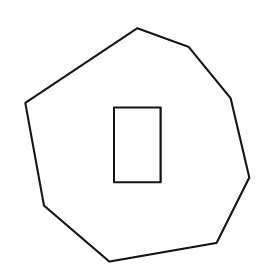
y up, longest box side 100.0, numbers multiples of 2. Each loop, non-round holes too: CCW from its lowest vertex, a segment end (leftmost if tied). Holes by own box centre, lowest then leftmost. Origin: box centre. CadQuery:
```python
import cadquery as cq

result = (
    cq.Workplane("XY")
    .moveTo(-12.0, -50.0)
    .lineTo(34.0, -42.0)
    .lineTo(48.0, -14.0)
    .lineTo(40.0, 20.0)
    .lineTo(22.0, 42.0)
    .lineTo(0.0, 50.0)
    .lineTo(-48.0, 18.0)
    .lineTo(-40.0, -26.0)
    .close()
    .moveTo(-10.0, -16.0)
    .lineTo(10.0, -16.0)
    .lineTo(10.0, 16.0)
    .lineTo(-10.0, 16.0)
    .close()
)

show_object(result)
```